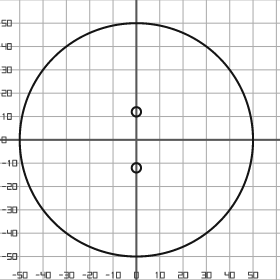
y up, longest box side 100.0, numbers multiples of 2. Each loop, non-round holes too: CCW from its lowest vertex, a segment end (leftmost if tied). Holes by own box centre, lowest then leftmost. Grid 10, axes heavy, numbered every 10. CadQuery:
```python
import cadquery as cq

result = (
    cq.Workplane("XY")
    .moveTo(0.0, 0.0)
    .circle(50.0)
    .moveTo(0.0, -12.0)
    .circle(2.0)
    .moveTo(0.0, 12.0)
    .circle(2.0)
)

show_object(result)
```